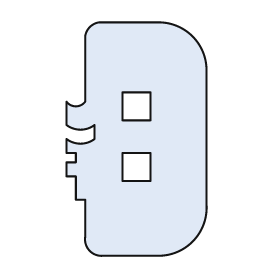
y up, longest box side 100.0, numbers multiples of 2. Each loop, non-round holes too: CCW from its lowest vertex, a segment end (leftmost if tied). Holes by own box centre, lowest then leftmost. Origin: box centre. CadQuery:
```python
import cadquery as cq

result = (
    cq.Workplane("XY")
    .moveTo(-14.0, -50.0)
    .lineTo(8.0, -50.0)
    .threePointArc((24.0, -44.0), (30.0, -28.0))
    .lineTo(30.0, 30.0)
    .threePointArc((24.0, 44.0), (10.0, 50.0))
    .lineTo(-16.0, 50.0)
    .threePointArc((-20.0, 48.0), (-22.0, 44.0))
    .lineTo(-22.0, 16.0)
    .threePointArc((-26.0, 14.0), (-30.0, 16.0))
    .lineTo(-30.0, 6.0)
    .threePointArc((-24.0, 4.0), (-18.0, 6.0))
    .lineTo(-18.0, 0.0)
    .threePointArc((-24.0, -2.0), (-30.0, 0.0))
    .lineTo(-30.0, -6.0)
    .lineTo(-26.0, -6.0)
    .lineTo(-26.0, -10.0)
    .lineTo(-30.0, -10.0)
    .lineTo(-30.0, -16.0)
    .lineTo(-26.0, -16.0)
    .lineTo(-26.0, -26.0)
    .lineTo(-22.0, -26.0)
    .lineTo(-22.0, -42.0)
    .threePointArc((-20.0, -48.0), (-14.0, -50.0))
    .close()
    .moveTo(-6.0, -18.0)
    .lineTo(6.0, -18.0)
    .lineTo(6.0, -6.0)
    .lineTo(-6.0, -6.0)
    .close()
    .moveTo(-6.0, 8.0)
    .lineTo(6.0, 8.0)
    .lineTo(6.0, 20.0)
    .lineTo(-6.0, 20.0)
    .close()
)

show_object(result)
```